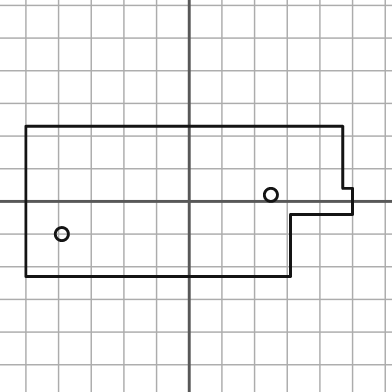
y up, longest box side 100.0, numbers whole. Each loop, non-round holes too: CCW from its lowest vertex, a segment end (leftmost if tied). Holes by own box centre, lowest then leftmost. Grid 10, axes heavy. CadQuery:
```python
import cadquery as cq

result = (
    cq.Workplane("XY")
    .moveTo(-50.0, -23.0)
    .lineTo(31.0, -23.0)
    .lineTo(31.0, -4.0)
    .lineTo(50.0, -4.0)
    .lineTo(50.0, 4.0)
    .lineTo(47.0, 4.0)
    .lineTo(47.0, 23.0)
    .lineTo(-50.0, 23.0)
    .close()
    .moveTo(-39.0, -10.0)
    .circle(2.0)
    .moveTo(25.0, 2.0)
    .circle(2.0)
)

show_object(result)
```